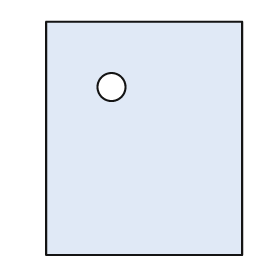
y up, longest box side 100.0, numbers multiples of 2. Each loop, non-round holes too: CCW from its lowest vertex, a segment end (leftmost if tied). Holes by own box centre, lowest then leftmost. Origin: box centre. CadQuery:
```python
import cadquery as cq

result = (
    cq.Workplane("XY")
    .moveTo(-42.0, -50.0)
    .lineTo(42.0, -50.0)
    .lineTo(42.0, 50.0)
    .lineTo(-42.0, 50.0)
    .close()
    .moveTo(-14.0, 22.0)
    .circle(6.0)
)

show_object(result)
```